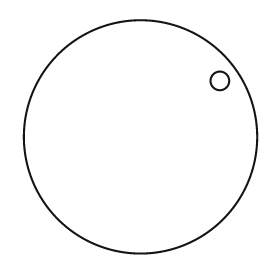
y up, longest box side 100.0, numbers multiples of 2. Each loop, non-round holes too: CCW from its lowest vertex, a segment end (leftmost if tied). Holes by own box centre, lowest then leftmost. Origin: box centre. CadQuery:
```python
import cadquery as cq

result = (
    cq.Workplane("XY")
    .moveTo(0.0, 0.0)
    .circle(50.0)
    .moveTo(34.0, 24.0)
    .circle(4.0)
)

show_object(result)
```